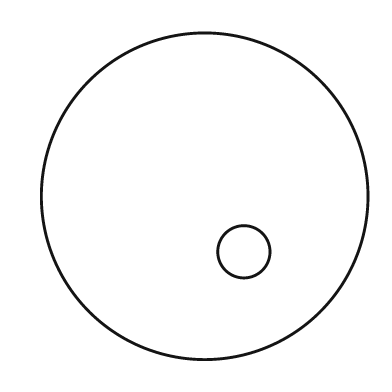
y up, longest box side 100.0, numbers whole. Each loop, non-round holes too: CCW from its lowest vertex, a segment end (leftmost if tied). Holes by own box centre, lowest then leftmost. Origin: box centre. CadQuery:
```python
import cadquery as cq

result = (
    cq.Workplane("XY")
    .moveTo(0.0, 0.0)
    .circle(50.0)
    .moveTo(12.0, -17.0)
    .circle(8.0)
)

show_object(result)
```